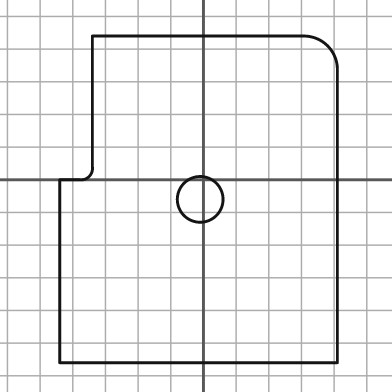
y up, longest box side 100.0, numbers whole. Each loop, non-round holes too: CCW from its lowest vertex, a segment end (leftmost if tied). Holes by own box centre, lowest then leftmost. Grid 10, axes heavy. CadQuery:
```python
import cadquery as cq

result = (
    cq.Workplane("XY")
    .moveTo(-44.0, -56.0)
    .lineTo(41.0, -56.0)
    .lineTo(41.0, 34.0)
    .threePointArc((38.0, 41.0), (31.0, 44.0))
    .lineTo(-34.0, 44.0)
    .lineTo(-34.0, 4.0)
    .threePointArc((-35.0, 1.0), (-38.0, 0.0))
    .lineTo(-44.0, 0.0)
    .close()
    .moveTo(-1.0, -6.0)
    .circle(7.0)
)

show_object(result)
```